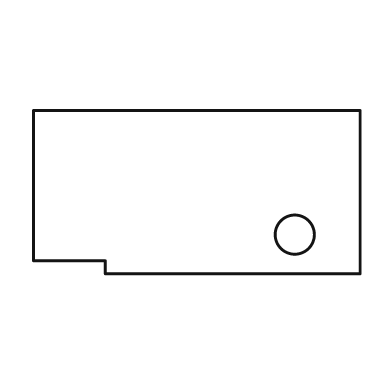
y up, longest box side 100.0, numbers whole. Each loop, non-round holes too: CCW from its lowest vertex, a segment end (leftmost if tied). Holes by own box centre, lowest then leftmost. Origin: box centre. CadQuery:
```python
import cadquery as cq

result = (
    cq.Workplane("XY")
    .moveTo(-28.0, -25.0)
    .lineTo(50.0, -25.0)
    .lineTo(50.0, 25.0)
    .lineTo(-50.0, 25.0)
    .lineTo(-50.0, -21.0)
    .lineTo(-28.0, -21.0)
    .close()
    .moveTo(30.0, -13.0)
    .circle(6.0)
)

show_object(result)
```